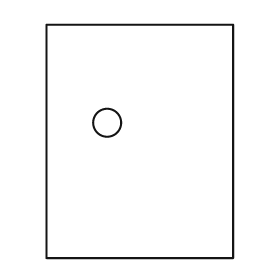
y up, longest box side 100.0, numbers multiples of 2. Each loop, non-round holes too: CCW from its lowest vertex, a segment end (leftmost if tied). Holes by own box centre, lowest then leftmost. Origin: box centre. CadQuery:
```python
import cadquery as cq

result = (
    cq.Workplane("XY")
    .moveTo(-40.0, -50.0)
    .lineTo(40.0, -50.0)
    .lineTo(40.0, 50.0)
    .lineTo(-40.0, 50.0)
    .close()
    .moveTo(-14.0, 8.0)
    .circle(6.0)
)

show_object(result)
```